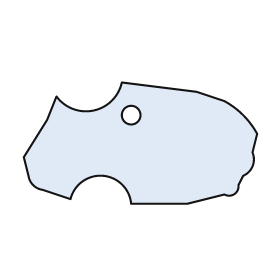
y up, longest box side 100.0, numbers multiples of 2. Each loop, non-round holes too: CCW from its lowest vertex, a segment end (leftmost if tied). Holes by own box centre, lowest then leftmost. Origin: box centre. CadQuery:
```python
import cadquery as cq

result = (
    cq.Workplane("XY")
    .moveTo(-4.0, -26.0)
    .lineTo(20.0, -26.0)
    .lineTo(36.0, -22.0)
    .threePointArc((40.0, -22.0), (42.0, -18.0))
    .lineTo(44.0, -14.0)
    .threePointArc((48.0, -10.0), (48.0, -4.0))
    .lineTo(50.0, 4.0)
    .threePointArc((44.0, 12.0), (36.0, 18.0))
    .lineTo(24.0, 22.0)
    .lineTo(-8.0, 26.0)
    .threePointArc((-20.0, 14.0), (-36.0, 20.0))
    .lineTo(-40.0, 10.0)
    .lineTo(-50.0, -6.0)
    .lineTo(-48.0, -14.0)
    .threePointArc((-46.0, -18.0), (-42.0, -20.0))
    .lineTo(-30.0, -24.0)
    .threePointArc((-16.0, -14.0), (-4.0, -26.0))
    .close()
    .moveTo(-4.0, 12.0)
    .circle(4.0)
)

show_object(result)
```